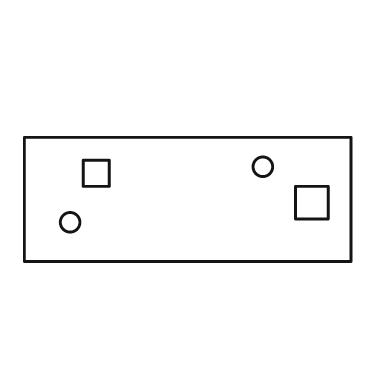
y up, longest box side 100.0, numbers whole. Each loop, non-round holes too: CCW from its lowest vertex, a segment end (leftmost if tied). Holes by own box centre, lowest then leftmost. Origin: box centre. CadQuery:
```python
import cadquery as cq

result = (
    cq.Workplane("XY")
    .moveTo(-50.0, -19.0)
    .lineTo(50.0, -19.0)
    .lineTo(50.0, 19.0)
    .lineTo(-50.0, 19.0)
    .close()
    .moveTo(-36.0, -7.0)
    .circle(3.0)
    .moveTo(33.0, -6.0)
    .lineTo(43.0, -6.0)
    .lineTo(43.0, 4.0)
    .lineTo(33.0, 4.0)
    .close()
    .moveTo(-32.0, 4.0)
    .lineTo(-24.0, 4.0)
    .lineTo(-24.0, 12.0)
    .lineTo(-32.0, 12.0)
    .close()
    .moveTo(23.0, 10.0)
    .circle(3.0)
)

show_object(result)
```